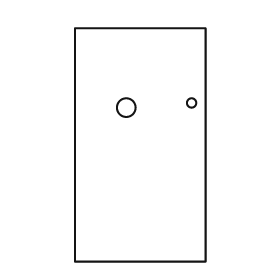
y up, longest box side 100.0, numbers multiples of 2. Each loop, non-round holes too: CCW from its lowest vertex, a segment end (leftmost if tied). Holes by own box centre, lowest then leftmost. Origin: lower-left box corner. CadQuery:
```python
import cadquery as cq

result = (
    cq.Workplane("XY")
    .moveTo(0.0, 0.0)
    .lineTo(56.0, 0.0)
    .lineTo(56.0, 100.0)
    .lineTo(0.0, 100.0)
    .close()
    .moveTo(22.0, 66.0)
    .circle(4.0)
    .moveTo(50.0, 68.0)
    .circle(2.0)
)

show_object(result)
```